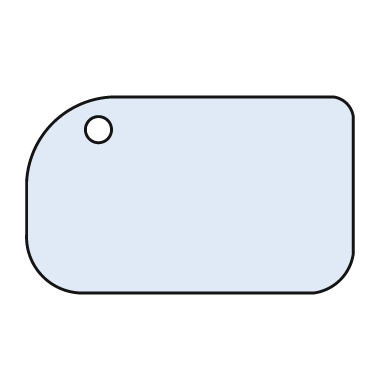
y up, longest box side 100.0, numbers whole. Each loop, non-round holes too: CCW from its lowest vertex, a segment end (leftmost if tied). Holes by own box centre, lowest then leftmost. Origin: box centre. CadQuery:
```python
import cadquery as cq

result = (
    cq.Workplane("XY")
    .moveTo(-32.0, -30.0)
    .lineTo(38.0, -30.0)
    .threePointArc((46.0, -26.0), (50.0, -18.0))
    .lineTo(50.0, 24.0)
    .threePointArc((48.0, 28.0), (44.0, 30.0))
    .lineTo(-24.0, 30.0)
    .threePointArc((-42.0, 22.0), (-50.0, 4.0))
    .lineTo(-50.0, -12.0)
    .threePointArc((-45.0, -25.0), (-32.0, -30.0))
    .close()
    .moveTo(-28.0, 20.0)
    .circle(4.0)
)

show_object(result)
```